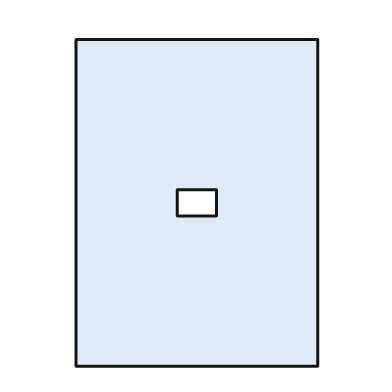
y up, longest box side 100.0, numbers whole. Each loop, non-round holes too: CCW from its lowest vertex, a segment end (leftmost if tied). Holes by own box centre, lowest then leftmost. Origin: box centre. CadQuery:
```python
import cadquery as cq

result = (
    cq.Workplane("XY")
    .moveTo(-37.0, -50.0)
    .lineTo(37.0, -50.0)
    .lineTo(37.0, 50.0)
    .lineTo(-37.0, 50.0)
    .close()
    .moveTo(-6.0, -4.0)
    .lineTo(6.0, -4.0)
    .lineTo(6.0, 4.0)
    .lineTo(-6.0, 4.0)
    .close()
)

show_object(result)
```